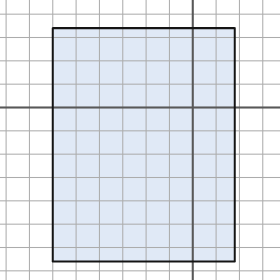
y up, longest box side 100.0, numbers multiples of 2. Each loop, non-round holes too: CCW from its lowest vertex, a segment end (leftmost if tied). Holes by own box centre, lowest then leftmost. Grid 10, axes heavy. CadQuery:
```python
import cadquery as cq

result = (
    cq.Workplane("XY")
    .moveTo(-60.0, -66.0)
    .lineTo(18.0, -66.0)
    .lineTo(18.0, 34.0)
    .lineTo(-60.0, 34.0)
    .close()
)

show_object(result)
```